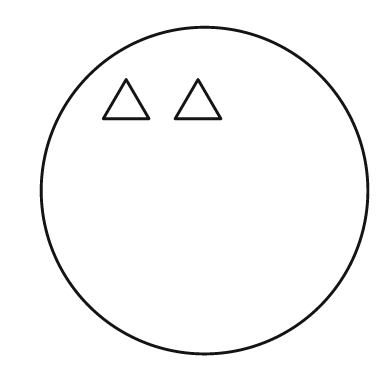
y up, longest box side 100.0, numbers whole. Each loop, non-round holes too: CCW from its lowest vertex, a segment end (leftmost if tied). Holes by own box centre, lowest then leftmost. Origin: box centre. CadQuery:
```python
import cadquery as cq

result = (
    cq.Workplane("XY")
    .moveTo(0.0, 0.0)
    .circle(50.0)
    .moveTo(-31.0, 22.0)
    .lineTo(-17.0, 22.0)
    .lineTo(-24.0, 34.0)
    .close()
    .moveTo(-9.0, 22.0)
    .lineTo(5.0, 22.0)
    .lineTo(-2.0, 34.0)
    .close()
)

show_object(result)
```